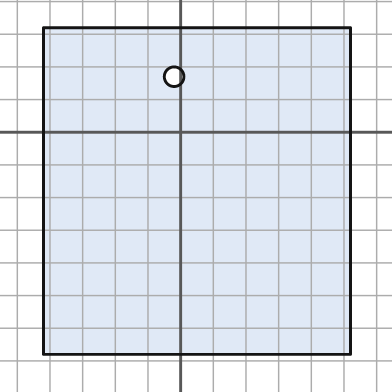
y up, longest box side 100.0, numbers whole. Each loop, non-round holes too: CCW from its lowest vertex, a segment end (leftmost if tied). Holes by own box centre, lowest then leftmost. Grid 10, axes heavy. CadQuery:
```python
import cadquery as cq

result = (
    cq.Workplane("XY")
    .moveTo(-42.0, -68.0)
    .lineTo(52.0, -68.0)
    .lineTo(52.0, 32.0)
    .lineTo(-42.0, 32.0)
    .close()
    .moveTo(-2.0, 17.0)
    .circle(3.0)
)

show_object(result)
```